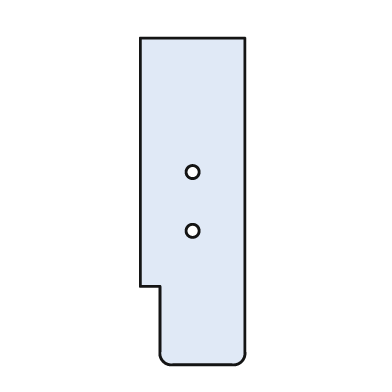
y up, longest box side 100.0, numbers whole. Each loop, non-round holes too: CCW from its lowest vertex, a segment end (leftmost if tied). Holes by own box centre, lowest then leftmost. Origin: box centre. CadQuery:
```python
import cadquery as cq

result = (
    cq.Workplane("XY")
    .moveTo(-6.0, -50.0)
    .lineTo(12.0, -50.0)
    .threePointArc((15.0, -49.0), (16.0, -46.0))
    .lineTo(16.0, 50.0)
    .lineTo(-16.0, 50.0)
    .lineTo(-16.0, -26.0)
    .lineTo(-10.0, -26.0)
    .lineTo(-10.0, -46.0)
    .threePointArc((-9.0, -49.0), (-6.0, -50.0))
    .close()
    .moveTo(0.0, -9.0)
    .circle(2.0)
    .moveTo(0.0, 9.0)
    .circle(2.0)
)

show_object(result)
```